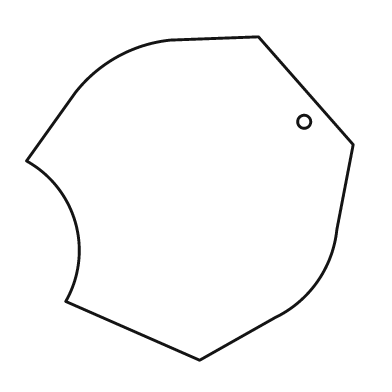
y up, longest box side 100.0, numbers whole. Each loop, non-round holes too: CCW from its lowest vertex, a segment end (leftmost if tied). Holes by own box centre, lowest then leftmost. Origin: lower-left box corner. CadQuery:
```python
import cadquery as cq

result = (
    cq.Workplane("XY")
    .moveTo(53.0, 0.0)
    .lineTo(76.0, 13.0)
    .threePointArc((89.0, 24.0), (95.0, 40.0))
    .lineTo(100.0, 66.0)
    .lineTo(71.0, 99.0)
    .lineTo(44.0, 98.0)
    .threePointArc((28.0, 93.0), (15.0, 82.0))
    .lineTo(0.0, 61.0)
    .threePointArc((15.0, 42.0), (12.0, 18.0))
    .close()
    .moveTo(85.0, 73.0)
    .circle(2.0)
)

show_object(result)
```